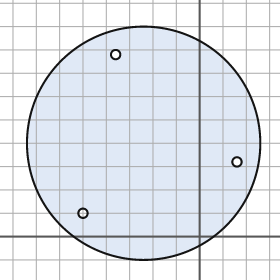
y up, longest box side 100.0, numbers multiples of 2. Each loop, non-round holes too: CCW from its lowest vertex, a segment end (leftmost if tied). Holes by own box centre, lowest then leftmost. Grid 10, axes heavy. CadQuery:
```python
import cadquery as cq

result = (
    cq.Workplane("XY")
    .moveTo(-24.0, 40.0)
    .circle(50.0)
    .moveTo(-50.0, 10.0)
    .circle(2.0)
    .moveTo(16.0, 32.0)
    .circle(2.0)
    .moveTo(-36.0, 78.0)
    .circle(2.0)
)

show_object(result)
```